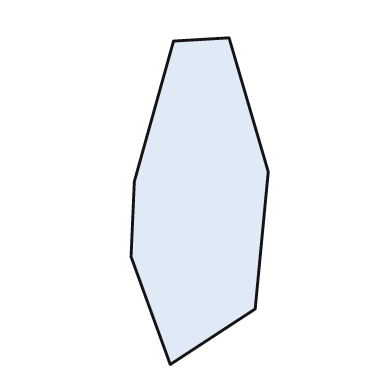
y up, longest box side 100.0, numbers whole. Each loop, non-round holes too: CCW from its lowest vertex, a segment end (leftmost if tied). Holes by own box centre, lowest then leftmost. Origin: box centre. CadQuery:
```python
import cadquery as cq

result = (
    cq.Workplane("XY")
    .moveTo(-9.0, -50.0)
    .lineTo(17.0, -33.0)
    .lineTo(21.0, 9.0)
    .lineTo(9.0, 50.0)
    .lineTo(-8.0, 49.0)
    .lineTo(-20.0, 6.0)
    .lineTo(-21.0, -17.0)
    .close()
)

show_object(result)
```